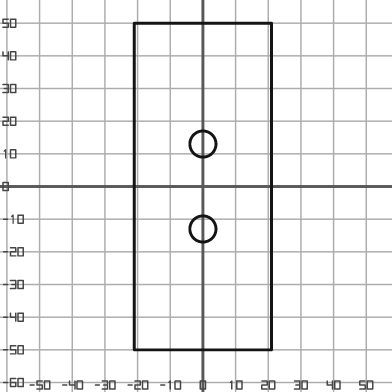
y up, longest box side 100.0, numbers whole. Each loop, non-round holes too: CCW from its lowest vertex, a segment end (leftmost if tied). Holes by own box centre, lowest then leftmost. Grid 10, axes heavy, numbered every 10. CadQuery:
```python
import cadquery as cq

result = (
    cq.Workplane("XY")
    .moveTo(-21.0, -50.0)
    .lineTo(21.0, -50.0)
    .lineTo(21.0, 50.0)
    .lineTo(-21.0, 50.0)
    .close()
    .moveTo(0.0, -13.0)
    .circle(4.0)
    .moveTo(0.0, 13.0)
    .circle(4.0)
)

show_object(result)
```